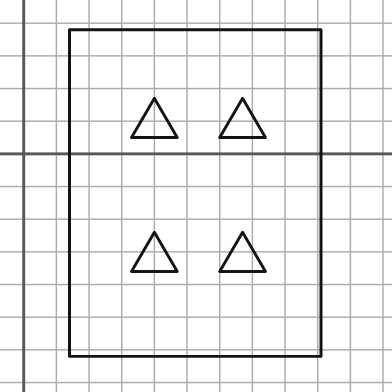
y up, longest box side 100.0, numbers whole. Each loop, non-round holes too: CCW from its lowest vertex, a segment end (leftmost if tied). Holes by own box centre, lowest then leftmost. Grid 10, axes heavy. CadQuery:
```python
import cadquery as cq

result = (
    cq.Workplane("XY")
    .moveTo(14.0, -62.0)
    .lineTo(91.0, -62.0)
    .lineTo(91.0, 38.0)
    .lineTo(14.0, 38.0)
    .close()
    .moveTo(33.0, -36.0)
    .lineTo(47.0, -36.0)
    .lineTo(40.0, -24.0)
    .close()
    .moveTo(60.0, -36.0)
    .lineTo(74.0, -36.0)
    .lineTo(67.0, -24.0)
    .close()
    .moveTo(33.0, 5.0)
    .lineTo(47.0, 5.0)
    .lineTo(40.0, 17.0)
    .close()
    .moveTo(60.0, 5.0)
    .lineTo(74.0, 5.0)
    .lineTo(67.0, 17.0)
    .close()
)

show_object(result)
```